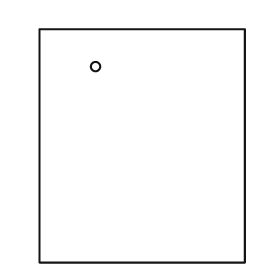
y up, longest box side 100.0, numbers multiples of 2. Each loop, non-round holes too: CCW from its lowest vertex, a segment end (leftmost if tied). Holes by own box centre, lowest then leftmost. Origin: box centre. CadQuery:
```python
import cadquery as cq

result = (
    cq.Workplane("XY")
    .moveTo(-44.0, -50.0)
    .lineTo(44.0, -50.0)
    .lineTo(44.0, 50.0)
    .lineTo(-44.0, 50.0)
    .close()
    .moveTo(-20.0, 34.0)
    .circle(2.0)
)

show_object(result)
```